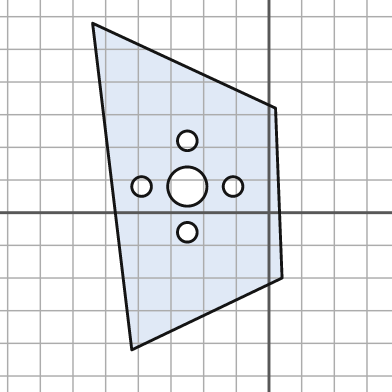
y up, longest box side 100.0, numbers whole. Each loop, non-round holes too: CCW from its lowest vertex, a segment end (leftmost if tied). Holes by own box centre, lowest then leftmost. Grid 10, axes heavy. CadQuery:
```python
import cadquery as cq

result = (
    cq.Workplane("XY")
    .moveTo(-42.0, -42.0)
    .lineTo(4.0, -20.0)
    .lineTo(2.0, 32.0)
    .lineTo(-54.0, 58.0)
    .close()
    .moveTo(-25.0, -6.0)
    .circle(3.0)
    .moveTo(-39.0, 8.0)
    .circle(3.0)
    .moveTo(-25.0, 8.0)
    .circle(6.0)
    .moveTo(-11.0, 8.0)
    .circle(3.0)
    .moveTo(-25.0, 22.0)
    .circle(3.0)
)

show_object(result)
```